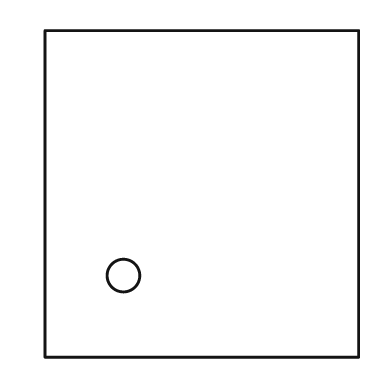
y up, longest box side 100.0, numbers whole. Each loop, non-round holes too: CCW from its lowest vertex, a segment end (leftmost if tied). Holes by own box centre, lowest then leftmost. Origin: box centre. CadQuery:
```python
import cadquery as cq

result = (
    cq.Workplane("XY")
    .moveTo(-48.0, -50.0)
    .lineTo(48.0, -50.0)
    .lineTo(48.0, 50.0)
    .lineTo(-48.0, 50.0)
    .close()
    .moveTo(-24.0, -25.0)
    .circle(5.0)
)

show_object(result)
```